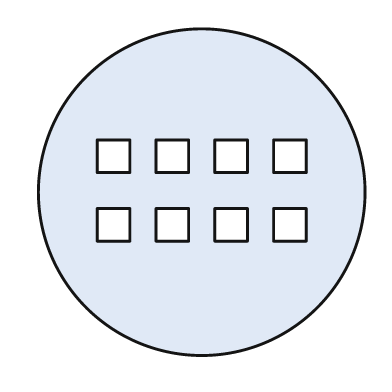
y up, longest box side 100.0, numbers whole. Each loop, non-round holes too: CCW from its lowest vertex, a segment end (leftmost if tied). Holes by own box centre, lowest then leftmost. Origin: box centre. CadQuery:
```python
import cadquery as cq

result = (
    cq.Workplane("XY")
    .moveTo(0.0, 0.0)
    .circle(50.0)
    .moveTo(-32.0, -15.0)
    .lineTo(-22.0, -15.0)
    .lineTo(-22.0, -5.0)
    .lineTo(-32.0, -5.0)
    .close()
    .moveTo(-14.0, -15.0)
    .lineTo(-4.0, -15.0)
    .lineTo(-4.0, -5.0)
    .lineTo(-14.0, -5.0)
    .close()
    .moveTo(4.0, -15.0)
    .lineTo(14.0, -15.0)
    .lineTo(14.0, -5.0)
    .lineTo(4.0, -5.0)
    .close()
    .moveTo(22.0, -15.0)
    .lineTo(32.0, -15.0)
    .lineTo(32.0, -5.0)
    .lineTo(22.0, -5.0)
    .close()
    .moveTo(-32.0, 6.0)
    .lineTo(-22.0, 6.0)
    .lineTo(-22.0, 16.0)
    .lineTo(-32.0, 16.0)
    .close()
    .moveTo(-14.0, 6.0)
    .lineTo(-4.0, 6.0)
    .lineTo(-4.0, 16.0)
    .lineTo(-14.0, 16.0)
    .close()
    .moveTo(4.0, 6.0)
    .lineTo(14.0, 6.0)
    .lineTo(14.0, 16.0)
    .lineTo(4.0, 16.0)
    .close()
    .moveTo(22.0, 6.0)
    .lineTo(32.0, 6.0)
    .lineTo(32.0, 16.0)
    .lineTo(22.0, 16.0)
    .close()
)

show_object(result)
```